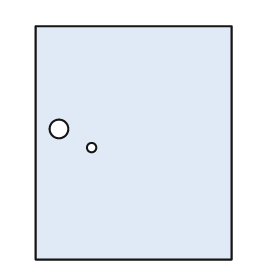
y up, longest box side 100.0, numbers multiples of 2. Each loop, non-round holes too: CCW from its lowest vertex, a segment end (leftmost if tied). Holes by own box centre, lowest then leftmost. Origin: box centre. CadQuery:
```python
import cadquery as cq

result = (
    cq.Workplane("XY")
    .moveTo(-42.0, -50.0)
    .lineTo(42.0, -50.0)
    .lineTo(42.0, 50.0)
    .lineTo(-42.0, 50.0)
    .close()
    .moveTo(-18.0, -2.0)
    .circle(2.0)
    .moveTo(-32.0, 6.0)
    .circle(4.0)
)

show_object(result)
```